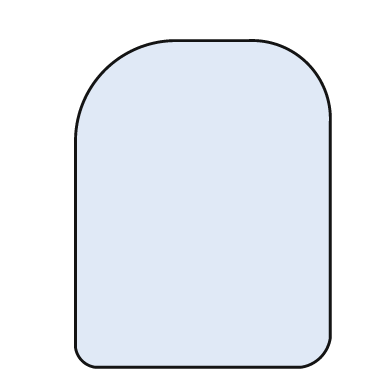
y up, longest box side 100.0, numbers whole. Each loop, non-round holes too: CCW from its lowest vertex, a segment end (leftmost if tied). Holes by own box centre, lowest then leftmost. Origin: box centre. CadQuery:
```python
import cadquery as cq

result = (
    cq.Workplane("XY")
    .moveTo(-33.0, -50.0)
    .lineTo(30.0, -50.0)
    .threePointArc((36.0, -47.0), (39.0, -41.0))
    .lineTo(39.0, 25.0)
    .threePointArc((32.0, 43.0), (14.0, 50.0))
    .lineTo(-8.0, 50.0)
    .threePointArc((-30.0, 41.0), (-39.0, 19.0))
    .lineTo(-39.0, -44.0)
    .threePointArc((-37.0, -48.0), (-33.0, -50.0))
    .close()
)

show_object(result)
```